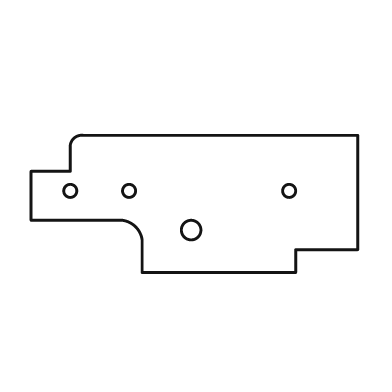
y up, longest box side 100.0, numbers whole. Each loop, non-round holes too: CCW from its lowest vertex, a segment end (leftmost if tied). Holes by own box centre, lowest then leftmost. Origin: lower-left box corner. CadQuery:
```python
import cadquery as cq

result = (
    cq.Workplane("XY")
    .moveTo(34.0, 0.0)
    .lineTo(81.0, 0.0)
    .lineTo(81.0, 7.0)
    .lineTo(100.0, 7.0)
    .lineTo(100.0, 42.0)
    .lineTo(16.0, 42.0)
    .threePointArc((13.0, 41.0), (12.0, 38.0))
    .lineTo(12.0, 31.0)
    .lineTo(0.0, 31.0)
    .lineTo(0.0, 16.0)
    .lineTo(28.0, 16.0)
    .threePointArc((32.0, 14.0), (34.0, 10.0))
    .close()
    .moveTo(49.0, 13.0)
    .circle(3.0)
    .moveTo(12.0, 25.0)
    .circle(2.0)
    .moveTo(30.0, 25.0)
    .circle(2.0)
    .moveTo(79.0, 25.0)
    .circle(2.0)
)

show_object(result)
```